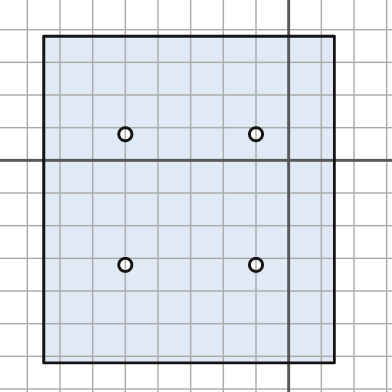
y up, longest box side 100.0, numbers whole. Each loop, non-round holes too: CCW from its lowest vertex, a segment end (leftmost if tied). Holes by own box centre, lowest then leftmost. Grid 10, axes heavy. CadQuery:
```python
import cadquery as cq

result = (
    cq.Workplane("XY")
    .moveTo(-75.0, -62.0)
    .lineTo(14.0, -62.0)
    .lineTo(14.0, 38.0)
    .lineTo(-75.0, 38.0)
    .close()
    .moveTo(-50.0, -32.0)
    .circle(2.0)
    .moveTo(-10.0, -32.0)
    .circle(2.0)
    .moveTo(-50.0, 8.0)
    .circle(2.0)
    .moveTo(-10.0, 8.0)
    .circle(2.0)
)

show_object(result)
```